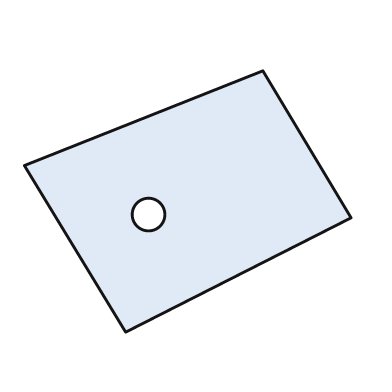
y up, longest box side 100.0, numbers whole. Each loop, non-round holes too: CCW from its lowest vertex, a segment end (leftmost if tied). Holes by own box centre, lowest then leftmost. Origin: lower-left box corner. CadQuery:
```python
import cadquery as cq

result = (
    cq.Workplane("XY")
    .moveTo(31.0, 0.0)
    .lineTo(100.0, 35.0)
    .lineTo(73.0, 80.0)
    .lineTo(0.0, 51.0)
    .close()
    .moveTo(38.0, 36.0)
    .circle(5.0)
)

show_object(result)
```